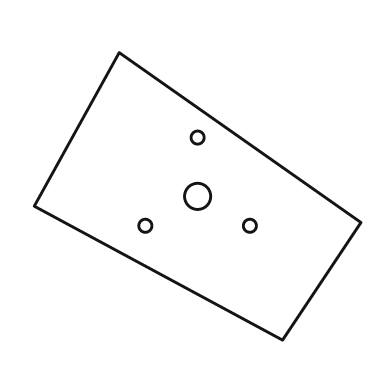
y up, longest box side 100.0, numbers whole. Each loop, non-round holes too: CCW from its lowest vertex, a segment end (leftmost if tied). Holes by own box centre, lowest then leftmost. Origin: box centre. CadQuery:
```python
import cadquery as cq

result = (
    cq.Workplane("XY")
    .moveTo(26.0, -44.0)
    .lineTo(50.0, -8.0)
    .lineTo(-24.0, 44.0)
    .lineTo(-50.0, -3.0)
    .close()
    .moveTo(-16.0, -9.0)
    .circle(2.0)
    .moveTo(16.0, -9.0)
    .circle(2.0)
    .moveTo(0.0, 0.0)
    .circle(4.0)
    .moveTo(0.0, 18.0)
    .circle(2.0)
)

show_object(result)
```